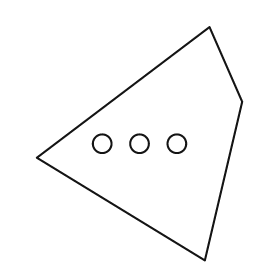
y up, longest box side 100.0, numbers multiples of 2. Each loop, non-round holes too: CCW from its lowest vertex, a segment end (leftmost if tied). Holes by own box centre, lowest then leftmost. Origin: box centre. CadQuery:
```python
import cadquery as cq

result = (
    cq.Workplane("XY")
    .moveTo(28.0, -50.0)
    .lineTo(44.0, 18.0)
    .lineTo(30.0, 50.0)
    .lineTo(-44.0, -6.0)
    .close()
    .moveTo(-16.0, 0.0)
    .circle(4.0)
    .moveTo(0.0, 0.0)
    .circle(4.0)
    .moveTo(16.0, 0.0)
    .circle(4.0)
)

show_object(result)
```